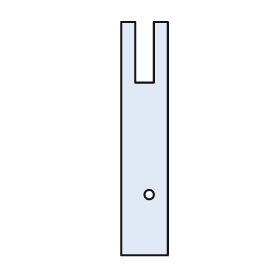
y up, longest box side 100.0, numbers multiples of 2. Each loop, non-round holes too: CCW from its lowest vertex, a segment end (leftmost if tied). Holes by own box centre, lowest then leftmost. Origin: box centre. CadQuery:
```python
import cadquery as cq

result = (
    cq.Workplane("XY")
    .moveTo(-10.0, -50.0)
    .lineTo(10.0, -50.0)
    .lineTo(10.0, 50.0)
    .lineTo(4.0, 50.0)
    .lineTo(4.0, 24.0)
    .lineTo(-4.0, 24.0)
    .lineTo(-4.0, 50.0)
    .lineTo(-10.0, 50.0)
    .close()
    .moveTo(2.0, -24.0)
    .circle(2.0)
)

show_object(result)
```